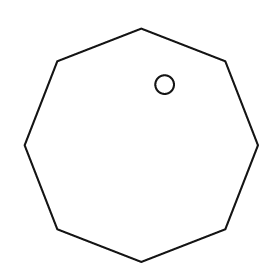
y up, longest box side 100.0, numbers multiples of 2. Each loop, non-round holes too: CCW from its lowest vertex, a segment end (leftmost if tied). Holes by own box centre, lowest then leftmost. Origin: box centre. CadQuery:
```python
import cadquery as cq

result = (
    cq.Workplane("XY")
    .moveTo(0.0, -50.0)
    .lineTo(36.0, -36.0)
    .lineTo(50.0, 0.0)
    .lineTo(36.0, 36.0)
    .lineTo(0.0, 50.0)
    .lineTo(-36.0, 36.0)
    .lineTo(-50.0, 0.0)
    .lineTo(-36.0, -36.0)
    .close()
    .moveTo(10.0, 26.0)
    .circle(4.0)
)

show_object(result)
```